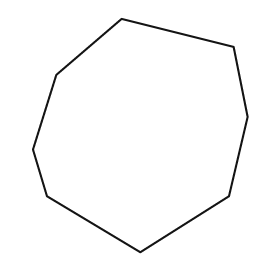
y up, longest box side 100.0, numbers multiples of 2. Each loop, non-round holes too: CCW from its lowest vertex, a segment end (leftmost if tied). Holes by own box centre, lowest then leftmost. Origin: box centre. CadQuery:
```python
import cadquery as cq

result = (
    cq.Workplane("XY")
    .moveTo(0.0, -50.0)
    .lineTo(38.0, -26.0)
    .lineTo(46.0, 8.0)
    .lineTo(40.0, 38.0)
    .lineTo(-8.0, 50.0)
    .lineTo(-36.0, 26.0)
    .lineTo(-46.0, -6.0)
    .lineTo(-40.0, -26.0)
    .close()
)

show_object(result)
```